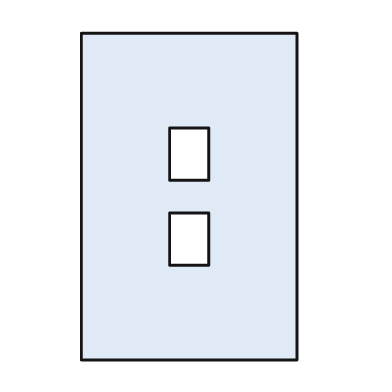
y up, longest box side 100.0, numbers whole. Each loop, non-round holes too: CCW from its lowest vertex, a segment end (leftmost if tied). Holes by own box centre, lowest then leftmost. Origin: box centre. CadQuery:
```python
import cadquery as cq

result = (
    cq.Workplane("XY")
    .moveTo(-33.0, -50.0)
    .lineTo(33.0, -50.0)
    .lineTo(33.0, 50.0)
    .lineTo(-33.0, 50.0)
    .close()
    .moveTo(-6.0, -21.0)
    .lineTo(6.0, -21.0)
    .lineTo(6.0, -5.0)
    .lineTo(-6.0, -5.0)
    .close()
    .moveTo(-6.0, 5.0)
    .lineTo(6.0, 5.0)
    .lineTo(6.0, 21.0)
    .lineTo(-6.0, 21.0)
    .close()
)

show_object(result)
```